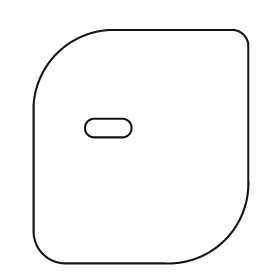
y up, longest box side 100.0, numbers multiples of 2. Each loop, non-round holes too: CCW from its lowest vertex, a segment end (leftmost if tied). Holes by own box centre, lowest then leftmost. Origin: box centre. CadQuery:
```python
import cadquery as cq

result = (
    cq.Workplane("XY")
    .moveTo(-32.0, -50.0)
    .lineTo(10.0, -50.0)
    .threePointArc((36.0, -40.0), (46.0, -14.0))
    .lineTo(46.0, 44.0)
    .threePointArc((44.0, 48.0), (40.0, 50.0))
    .lineTo(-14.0, 50.0)
    .threePointArc((-36.0, 40.0), (-46.0, 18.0))
    .lineTo(-46.0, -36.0)
    .threePointArc((-42.0, -46.0), (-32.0, -50.0))
    .close()
    .moveTo(-20.0, 4.0)
    .lineTo(-8.0, 4.0)
    .threePointArc((-4.0, 8.0), (-8.0, 12.0))
    .lineTo(-20.0, 12.0)
    .threePointArc((-24.0, 8.0), (-20.0, 4.0))
    .close()
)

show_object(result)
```